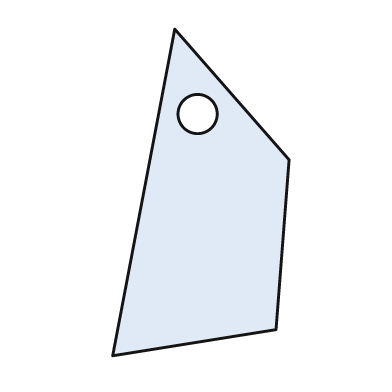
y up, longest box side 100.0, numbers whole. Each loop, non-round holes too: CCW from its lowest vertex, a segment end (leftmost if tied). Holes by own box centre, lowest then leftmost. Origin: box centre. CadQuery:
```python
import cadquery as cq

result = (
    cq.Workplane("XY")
    .moveTo(-27.0, -50.0)
    .lineTo(23.0, -42.0)
    .lineTo(27.0, 10.0)
    .lineTo(-8.0, 50.0)
    .close()
    .moveTo(-1.0, 24.0)
    .circle(6.0)
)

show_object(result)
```